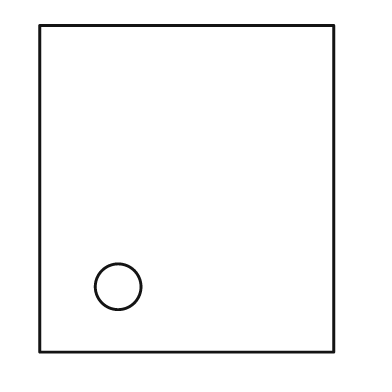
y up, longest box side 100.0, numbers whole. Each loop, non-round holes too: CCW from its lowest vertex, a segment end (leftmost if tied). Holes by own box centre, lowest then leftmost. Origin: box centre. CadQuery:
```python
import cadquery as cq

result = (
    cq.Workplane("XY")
    .moveTo(-45.0, -50.0)
    .lineTo(45.0, -50.0)
    .lineTo(45.0, 50.0)
    .lineTo(-45.0, 50.0)
    .close()
    .moveTo(-21.0, -30.0)
    .circle(7.0)
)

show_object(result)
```